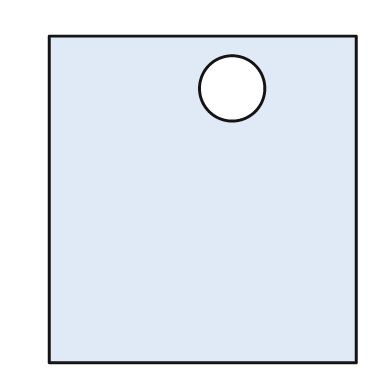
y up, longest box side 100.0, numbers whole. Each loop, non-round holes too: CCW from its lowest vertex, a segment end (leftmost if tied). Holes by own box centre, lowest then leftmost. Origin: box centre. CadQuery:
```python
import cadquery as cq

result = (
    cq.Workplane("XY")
    .moveTo(-47.0, -50.0)
    .lineTo(47.0, -50.0)
    .lineTo(47.0, 50.0)
    .lineTo(-47.0, 50.0)
    .close()
    .moveTo(9.0, 34.0)
    .circle(10.0)
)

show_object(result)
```